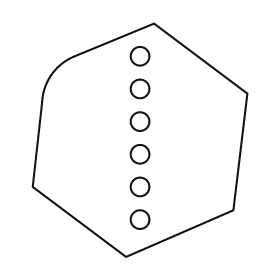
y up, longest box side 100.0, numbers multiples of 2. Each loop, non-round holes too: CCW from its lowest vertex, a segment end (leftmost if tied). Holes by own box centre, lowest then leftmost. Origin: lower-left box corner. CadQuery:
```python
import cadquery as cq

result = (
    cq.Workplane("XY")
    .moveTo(40.0, 0.0)
    .lineTo(86.0, 20.0)
    .lineTo(92.0, 70.0)
    .lineTo(52.0, 100.0)
    .lineTo(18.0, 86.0)
    .threePointArc((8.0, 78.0), (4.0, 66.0))
    .lineTo(0.0, 30.0)
    .close()
    .moveTo(46.0, 16.0)
    .circle(4.0)
    .moveTo(46.0, 30.0)
    .circle(4.0)
    .moveTo(46.0, 44.0)
    .circle(4.0)
    .moveTo(46.0, 58.0)
    .circle(4.0)
    .moveTo(46.0, 72.0)
    .circle(4.0)
    .moveTo(46.0, 86.0)
    .circle(4.0)
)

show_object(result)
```